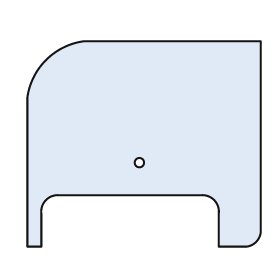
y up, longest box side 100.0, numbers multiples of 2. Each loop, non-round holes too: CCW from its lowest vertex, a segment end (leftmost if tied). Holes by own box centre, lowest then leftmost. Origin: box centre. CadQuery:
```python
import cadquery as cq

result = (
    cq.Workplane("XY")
    .moveTo(-50.0, -44.0)
    .lineTo(-44.0, -44.0)
    .lineTo(-44.0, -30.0)
    .threePointArc((-42.0, -24.0), (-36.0, -22.0))
    .lineTo(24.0, -22.0)
    .threePointArc((30.0, -24.0), (32.0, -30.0))
    .lineTo(32.0, -44.0)
    .lineTo(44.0, -44.0)
    .threePointArc((48.0, -42.0), (50.0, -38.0))
    .lineTo(50.0, 44.0)
    .lineTo(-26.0, 44.0)
    .threePointArc((-42.0, 36.0), (-50.0, 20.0))
    .close()
    .moveTo(-2.0, -8.0)
    .circle(2.0)
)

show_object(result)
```